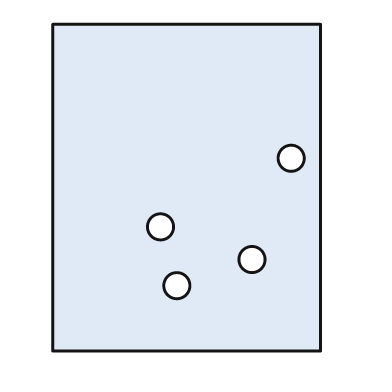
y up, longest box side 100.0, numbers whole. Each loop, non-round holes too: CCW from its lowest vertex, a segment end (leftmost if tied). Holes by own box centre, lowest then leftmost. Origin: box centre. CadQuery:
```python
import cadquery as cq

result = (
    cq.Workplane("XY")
    .moveTo(-41.0, -50.0)
    .lineTo(41.0, -50.0)
    .lineTo(41.0, 50.0)
    .lineTo(-41.0, 50.0)
    .close()
    .moveTo(-3.0, -30.0)
    .circle(4.0)
    .moveTo(20.0, -22.0)
    .circle(4.0)
    .moveTo(-8.0, -12.0)
    .circle(4.0)
    .moveTo(32.0, 9.0)
    .circle(4.0)
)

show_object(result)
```